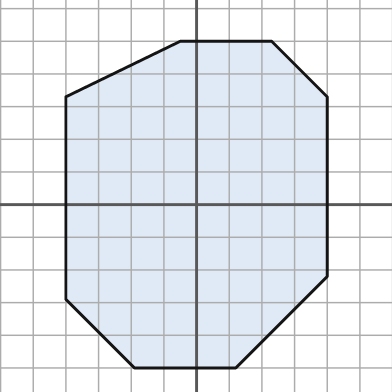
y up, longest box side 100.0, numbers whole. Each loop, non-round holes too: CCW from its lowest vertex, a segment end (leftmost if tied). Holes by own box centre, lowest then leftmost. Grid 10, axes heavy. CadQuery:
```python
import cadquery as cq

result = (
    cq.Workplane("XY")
    .moveTo(-19.0, -50.0)
    .lineTo(12.0, -50.0)
    .lineTo(40.0, -22.0)
    .lineTo(40.0, 33.0)
    .lineTo(23.0, 50.0)
    .lineTo(-5.0, 50.0)
    .lineTo(-40.0, 33.0)
    .lineTo(-40.0, -29.0)
    .close()
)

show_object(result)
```